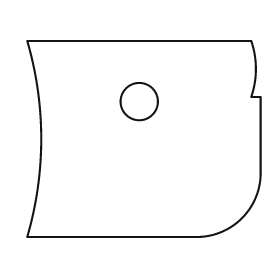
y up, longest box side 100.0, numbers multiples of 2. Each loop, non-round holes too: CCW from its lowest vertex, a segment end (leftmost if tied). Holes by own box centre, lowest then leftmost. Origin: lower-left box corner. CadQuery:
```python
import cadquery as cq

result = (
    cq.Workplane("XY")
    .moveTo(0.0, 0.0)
    .lineTo(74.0, 0.0)
    .threePointArc((92.0, 8.0), (100.0, 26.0))
    .lineTo(100.0, 60.0)
    .lineTo(96.0, 60.0)
    .threePointArc((98.0, 72.0), (96.0, 84.0))
    .lineTo(0.0, 84.0)
    .threePointArc((6.0, 42.0), (0.0, 0.0))
    .close()
    .moveTo(48.0, 58.0)
    .circle(8.0)
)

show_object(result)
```